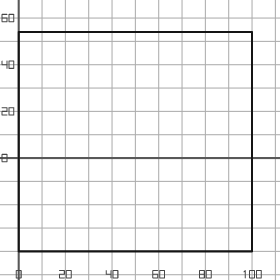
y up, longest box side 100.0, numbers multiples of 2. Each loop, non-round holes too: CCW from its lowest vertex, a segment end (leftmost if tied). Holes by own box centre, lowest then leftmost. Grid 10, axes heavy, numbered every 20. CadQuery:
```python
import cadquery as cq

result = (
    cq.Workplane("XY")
    .moveTo(0.0, -40.0)
    .lineTo(100.0, -40.0)
    .lineTo(100.0, 54.0)
    .lineTo(0.0, 54.0)
    .close()
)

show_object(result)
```